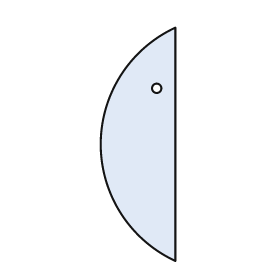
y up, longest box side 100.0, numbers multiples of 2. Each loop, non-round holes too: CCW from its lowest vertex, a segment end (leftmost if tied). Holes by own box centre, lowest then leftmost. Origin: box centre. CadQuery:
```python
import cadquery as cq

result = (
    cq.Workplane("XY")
    .moveTo(16.0, -50.0)
    .lineTo(16.0, 50.0)
    .threePointArc((-16.0, 0.0), (16.0, -50.0))
    .close()
    .moveTo(8.0, 24.0)
    .circle(2.0)
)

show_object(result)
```